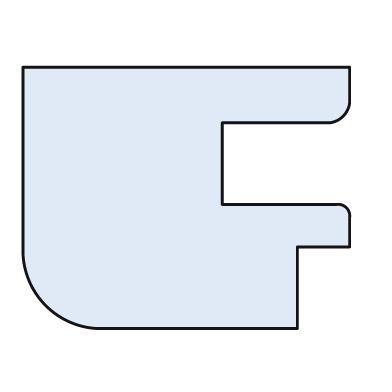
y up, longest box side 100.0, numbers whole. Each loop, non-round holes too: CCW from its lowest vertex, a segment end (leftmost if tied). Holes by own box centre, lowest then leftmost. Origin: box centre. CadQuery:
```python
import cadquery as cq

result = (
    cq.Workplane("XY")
    .moveTo(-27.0, -40.0)
    .lineTo(34.0, -40.0)
    .lineTo(34.0, -15.0)
    .lineTo(50.0, -15.0)
    .lineTo(50.0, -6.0)
    .threePointArc((49.0, -3.0), (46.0, -2.0))
    .lineTo(11.0, -2.0)
    .lineTo(11.0, 23.0)
    .lineTo(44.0, 23.0)
    .threePointArc((48.0, 25.0), (50.0, 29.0))
    .lineTo(50.0, 40.0)
    .lineTo(-50.0, 40.0)
    .lineTo(-50.0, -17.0)
    .threePointArc((-43.0, -33.0), (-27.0, -40.0))
    .close()
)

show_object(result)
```